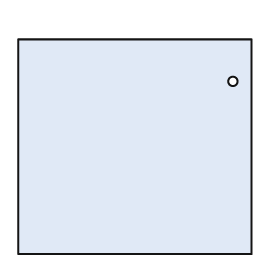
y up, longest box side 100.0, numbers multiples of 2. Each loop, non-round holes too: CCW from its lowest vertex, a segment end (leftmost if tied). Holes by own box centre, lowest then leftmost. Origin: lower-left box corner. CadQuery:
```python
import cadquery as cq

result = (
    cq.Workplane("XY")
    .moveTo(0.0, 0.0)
    .lineTo(100.0, 0.0)
    .lineTo(100.0, 92.0)
    .lineTo(0.0, 92.0)
    .close()
    .moveTo(92.0, 74.0)
    .circle(2.0)
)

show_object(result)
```